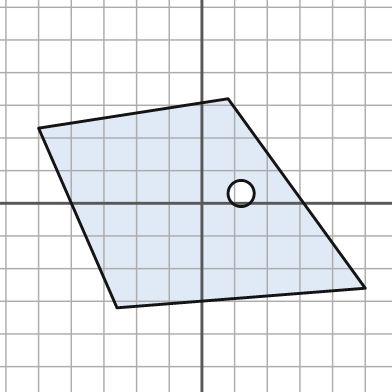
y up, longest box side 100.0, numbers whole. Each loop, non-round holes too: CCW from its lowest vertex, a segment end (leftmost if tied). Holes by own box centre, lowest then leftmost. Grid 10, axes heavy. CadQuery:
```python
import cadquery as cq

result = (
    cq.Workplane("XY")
    .moveTo(-26.0, -32.0)
    .lineTo(50.0, -26.0)
    .lineTo(8.0, 32.0)
    .lineTo(-50.0, 23.0)
    .close()
    .moveTo(12.0, 3.0)
    .circle(4.0)
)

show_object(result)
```